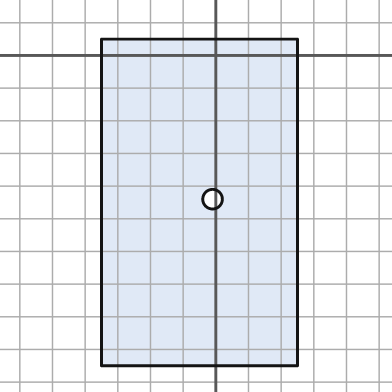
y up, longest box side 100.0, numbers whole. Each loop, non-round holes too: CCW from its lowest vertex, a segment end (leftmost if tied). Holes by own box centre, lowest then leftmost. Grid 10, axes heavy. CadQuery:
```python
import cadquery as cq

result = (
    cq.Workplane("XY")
    .moveTo(-35.0, -95.0)
    .lineTo(25.0, -95.0)
    .lineTo(25.0, 5.0)
    .lineTo(-35.0, 5.0)
    .close()
    .moveTo(-1.0, -44.0)
    .circle(3.0)
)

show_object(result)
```